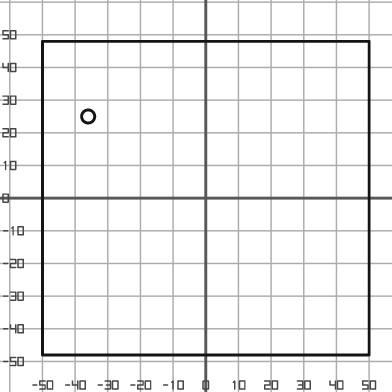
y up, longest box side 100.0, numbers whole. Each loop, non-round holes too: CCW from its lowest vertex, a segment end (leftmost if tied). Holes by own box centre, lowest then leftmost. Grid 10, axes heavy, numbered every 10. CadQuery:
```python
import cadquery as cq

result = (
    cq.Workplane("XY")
    .moveTo(-50.0, -48.0)
    .lineTo(50.0, -48.0)
    .lineTo(50.0, 48.0)
    .lineTo(-50.0, 48.0)
    .close()
    .moveTo(-36.0, 25.0)
    .circle(2.0)
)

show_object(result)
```